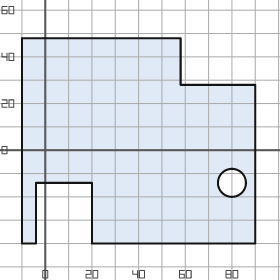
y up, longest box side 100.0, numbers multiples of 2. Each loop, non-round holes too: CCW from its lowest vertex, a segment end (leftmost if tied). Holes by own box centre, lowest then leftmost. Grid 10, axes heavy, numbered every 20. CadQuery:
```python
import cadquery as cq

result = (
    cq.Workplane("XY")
    .moveTo(-10.0, -40.0)
    .lineTo(-4.0, -40.0)
    .lineTo(-4.0, -14.0)
    .lineTo(20.0, -14.0)
    .lineTo(20.0, -40.0)
    .lineTo(90.0, -40.0)
    .lineTo(90.0, 28.0)
    .lineTo(58.0, 28.0)
    .lineTo(58.0, 48.0)
    .lineTo(-10.0, 48.0)
    .close()
    .moveTo(80.0, -14.0)
    .circle(6.0)
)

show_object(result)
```